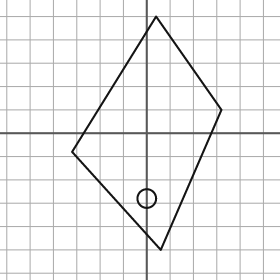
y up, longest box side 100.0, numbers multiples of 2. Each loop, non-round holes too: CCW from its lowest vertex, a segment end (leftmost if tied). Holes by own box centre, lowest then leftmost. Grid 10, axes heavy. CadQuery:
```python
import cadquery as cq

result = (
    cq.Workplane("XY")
    .moveTo(6.0, -50.0)
    .lineTo(32.0, 10.0)
    .lineTo(4.0, 50.0)
    .lineTo(-32.0, -8.0)
    .close()
    .moveTo(0.0, -28.0)
    .circle(4.0)
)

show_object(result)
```